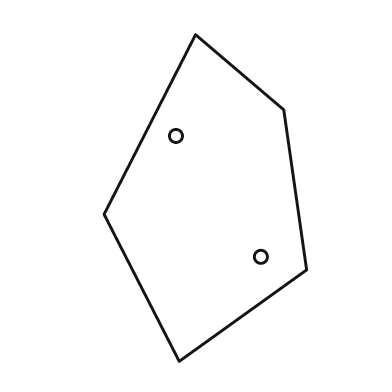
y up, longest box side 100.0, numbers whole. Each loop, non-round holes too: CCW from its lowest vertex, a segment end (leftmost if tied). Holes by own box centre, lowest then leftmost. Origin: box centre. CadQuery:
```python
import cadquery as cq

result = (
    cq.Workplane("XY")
    .moveTo(-8.0, -50.0)
    .lineTo(31.0, -22.0)
    .lineTo(24.0, 27.0)
    .lineTo(-3.0, 50.0)
    .lineTo(-31.0, -5.0)
    .close()
    .moveTo(17.0, -18.0)
    .circle(2.0)
    .moveTo(-9.0, 19.0)
    .circle(2.0)
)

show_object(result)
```